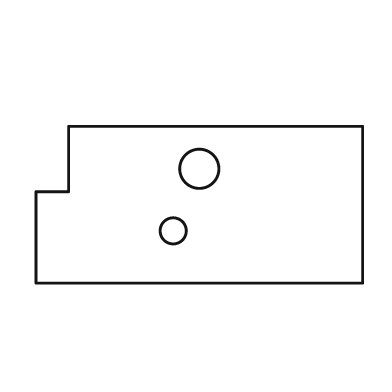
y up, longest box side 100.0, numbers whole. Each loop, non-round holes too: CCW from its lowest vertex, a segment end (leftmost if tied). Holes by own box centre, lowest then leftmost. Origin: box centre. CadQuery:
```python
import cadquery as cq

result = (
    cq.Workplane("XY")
    .moveTo(-50.0, -24.0)
    .lineTo(50.0, -24.0)
    .lineTo(50.0, 24.0)
    .lineTo(-40.0, 24.0)
    .lineTo(-40.0, 4.0)
    .lineTo(-50.0, 4.0)
    .close()
    .moveTo(-8.0, -8.0)
    .circle(4.0)
    .moveTo(0.0, 11.0)
    .circle(6.0)
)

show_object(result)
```